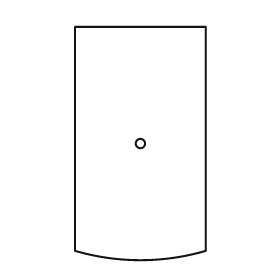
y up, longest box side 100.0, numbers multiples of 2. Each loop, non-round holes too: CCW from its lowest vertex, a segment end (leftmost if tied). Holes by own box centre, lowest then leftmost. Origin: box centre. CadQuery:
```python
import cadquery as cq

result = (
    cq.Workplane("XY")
    .moveTo(-28.0, -46.0)
    .threePointArc((0.0, -50.0), (28.0, -46.0))
    .lineTo(28.0, 50.0)
    .lineTo(-28.0, 50.0)
    .close()
    .moveTo(0.0, 0.0)
    .circle(2.0)
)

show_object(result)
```